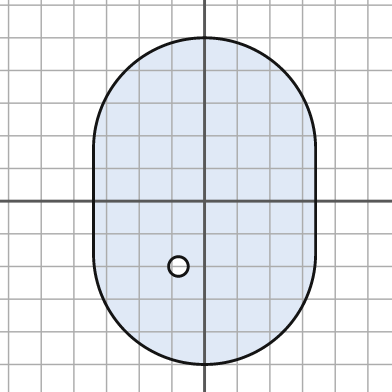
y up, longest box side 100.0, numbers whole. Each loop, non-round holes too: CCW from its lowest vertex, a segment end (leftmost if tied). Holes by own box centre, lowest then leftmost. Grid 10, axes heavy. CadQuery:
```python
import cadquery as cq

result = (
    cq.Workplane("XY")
    .moveTo(-34.0, -16.0)
    .threePointArc((0.0, -50.0), (34.0, -16.0))
    .lineTo(34.0, 16.0)
    .threePointArc((0.0, 50.0), (-34.0, 16.0))
    .close()
    .moveTo(-8.0, -20.0)
    .circle(3.0)
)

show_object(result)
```